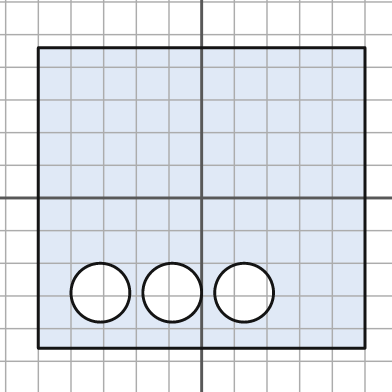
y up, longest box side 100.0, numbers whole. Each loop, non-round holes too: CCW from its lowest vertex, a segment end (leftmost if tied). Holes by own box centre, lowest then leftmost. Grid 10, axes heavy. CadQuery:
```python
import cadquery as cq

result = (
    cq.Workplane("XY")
    .moveTo(-50.0, -46.0)
    .lineTo(50.0, -46.0)
    .lineTo(50.0, 46.0)
    .lineTo(-50.0, 46.0)
    .close()
    .moveTo(-31.0, -29.0)
    .circle(9.0)
    .moveTo(-9.0, -29.0)
    .circle(9.0)
    .moveTo(13.0, -29.0)
    .circle(9.0)
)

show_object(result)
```